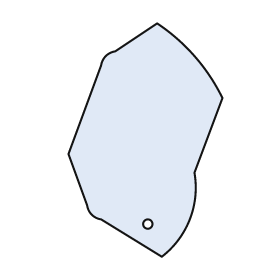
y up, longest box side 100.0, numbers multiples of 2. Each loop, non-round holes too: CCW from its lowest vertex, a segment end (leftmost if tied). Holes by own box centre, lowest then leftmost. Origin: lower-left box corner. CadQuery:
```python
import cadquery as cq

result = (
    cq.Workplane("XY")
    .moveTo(40.0, 0.0)
    .threePointArc((52.0, 16.0), (54.0, 36.0))
    .lineTo(66.0, 68.0)
    .threePointArc((54.0, 86.0), (38.0, 100.0))
    .lineTo(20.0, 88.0)
    .threePointArc((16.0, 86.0), (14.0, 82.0))
    .lineTo(0.0, 44.0)
    .lineTo(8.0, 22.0)
    .threePointArc((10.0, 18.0), (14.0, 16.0))
    .close()
    .moveTo(34.0, 14.0)
    .circle(2.0)
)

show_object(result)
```